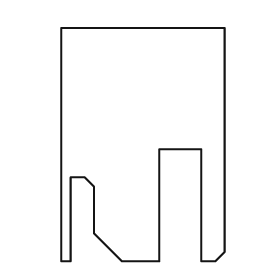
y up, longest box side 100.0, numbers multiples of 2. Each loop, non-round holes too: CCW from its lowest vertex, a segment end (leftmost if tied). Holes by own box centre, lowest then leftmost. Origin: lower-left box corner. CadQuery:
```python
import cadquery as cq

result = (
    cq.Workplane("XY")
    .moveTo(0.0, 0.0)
    .lineTo(4.0, 0.0)
    .lineTo(4.0, 36.0)
    .lineTo(10.0, 36.0)
    .lineTo(14.0, 32.0)
    .lineTo(14.0, 12.0)
    .lineTo(26.0, 0.0)
    .lineTo(42.0, 0.0)
    .lineTo(42.0, 48.0)
    .lineTo(60.0, 48.0)
    .lineTo(60.0, 0.0)
    .lineTo(66.0, 0.0)
    .lineTo(70.0, 4.0)
    .lineTo(70.0, 100.0)
    .lineTo(0.0, 100.0)
    .close()
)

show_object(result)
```